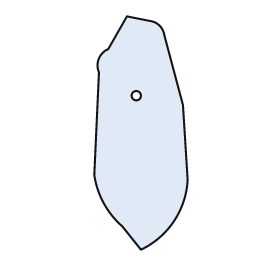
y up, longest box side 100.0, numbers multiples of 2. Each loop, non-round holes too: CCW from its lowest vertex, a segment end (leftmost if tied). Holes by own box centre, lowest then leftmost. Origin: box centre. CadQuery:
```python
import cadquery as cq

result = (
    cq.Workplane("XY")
    .moveTo(0.0, -50.0)
    .threePointArc((14.0, -38.0), (20.0, -20.0))
    .lineTo(18.0, 12.0)
    .lineTo(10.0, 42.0)
    .threePointArc((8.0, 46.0), (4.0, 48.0))
    .lineTo(-6.0, 50.0)
    .lineTo(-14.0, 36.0)
    .threePointArc((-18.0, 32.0), (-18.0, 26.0))
    .lineTo(-20.0, -18.0)
    .threePointArc((-16.0, -30.0), (-8.0, -40.0))
    .close()
    .moveTo(-2.0, 16.0)
    .circle(2.0)
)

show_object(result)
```